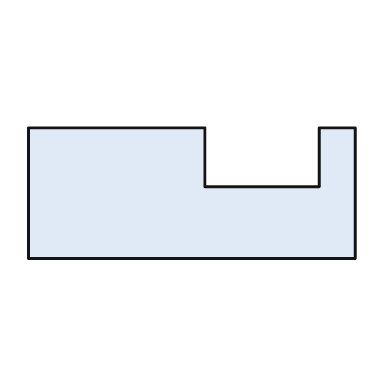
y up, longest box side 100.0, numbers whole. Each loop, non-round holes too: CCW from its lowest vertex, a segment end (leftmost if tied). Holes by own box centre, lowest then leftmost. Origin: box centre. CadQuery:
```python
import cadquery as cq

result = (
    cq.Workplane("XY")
    .moveTo(-50.0, -20.0)
    .lineTo(50.0, -20.0)
    .lineTo(50.0, 20.0)
    .lineTo(39.0, 20.0)
    .lineTo(39.0, 2.0)
    .lineTo(4.0, 2.0)
    .lineTo(4.0, 20.0)
    .lineTo(-50.0, 20.0)
    .close()
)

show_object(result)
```